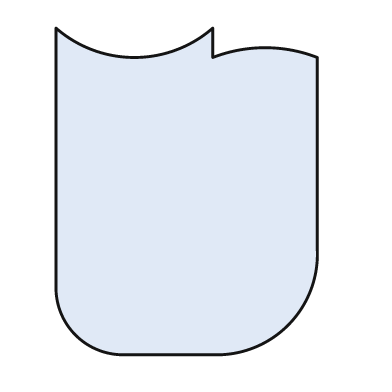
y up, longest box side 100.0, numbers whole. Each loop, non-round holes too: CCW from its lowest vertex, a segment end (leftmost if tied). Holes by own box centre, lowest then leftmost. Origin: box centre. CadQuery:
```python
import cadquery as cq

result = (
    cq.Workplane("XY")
    .moveTo(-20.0, -50.0)
    .lineTo(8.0, -50.0)
    .threePointArc((31.0, -41.0), (40.0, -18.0))
    .lineTo(40.0, 41.0)
    .threePointArc((24.0, 44.0), (8.0, 41.0))
    .lineTo(8.0, 50.0)
    .threePointArc((-16.0, 41.0), (-40.0, 50.0))
    .lineTo(-40.0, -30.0)
    .threePointArc((-34.0, -44.0), (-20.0, -50.0))
    .close()
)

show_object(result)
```